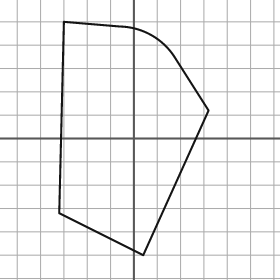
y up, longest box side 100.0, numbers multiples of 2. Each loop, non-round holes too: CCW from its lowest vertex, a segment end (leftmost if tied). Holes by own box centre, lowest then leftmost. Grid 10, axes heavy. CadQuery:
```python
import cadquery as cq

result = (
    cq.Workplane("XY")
    .moveTo(4.0, -50.0)
    .lineTo(32.0, 12.0)
    .lineTo(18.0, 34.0)
    .threePointArc((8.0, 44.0), (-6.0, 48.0))
    .lineTo(-30.0, 50.0)
    .lineTo(-32.0, -32.0)
    .close()
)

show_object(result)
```